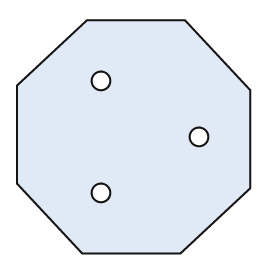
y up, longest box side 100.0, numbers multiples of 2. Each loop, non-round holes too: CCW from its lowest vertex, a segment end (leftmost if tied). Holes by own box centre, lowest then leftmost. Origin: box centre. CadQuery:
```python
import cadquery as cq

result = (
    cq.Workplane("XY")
    .moveTo(-22.0, -50.0)
    .lineTo(20.0, -50.0)
    .lineTo(50.0, -22.0)
    .lineTo(50.0, 20.0)
    .lineTo(22.0, 50.0)
    .lineTo(-20.0, 50.0)
    .lineTo(-50.0, 22.0)
    .lineTo(-50.0, -20.0)
    .close()
    .moveTo(-14.0, -24.0)
    .circle(4.0)
    .moveTo(28.0, 0.0)
    .circle(4.0)
    .moveTo(-14.0, 24.0)
    .circle(4.0)
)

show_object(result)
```